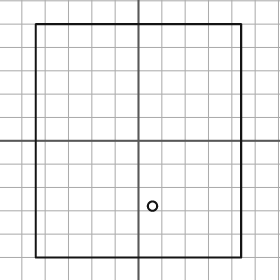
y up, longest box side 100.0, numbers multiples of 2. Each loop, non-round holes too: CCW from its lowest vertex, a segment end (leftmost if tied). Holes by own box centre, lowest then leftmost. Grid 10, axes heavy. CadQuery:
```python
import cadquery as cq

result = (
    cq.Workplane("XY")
    .moveTo(-44.0, -50.0)
    .lineTo(44.0, -50.0)
    .lineTo(44.0, 50.0)
    .lineTo(-44.0, 50.0)
    .close()
    .moveTo(6.0, -28.0)
    .circle(2.0)
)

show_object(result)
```